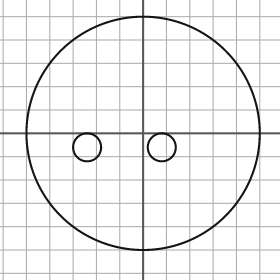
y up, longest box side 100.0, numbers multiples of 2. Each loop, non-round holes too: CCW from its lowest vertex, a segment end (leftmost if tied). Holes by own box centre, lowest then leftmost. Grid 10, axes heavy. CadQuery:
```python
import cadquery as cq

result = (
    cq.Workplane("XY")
    .moveTo(0.0, 0.0)
    .circle(50.0)
    .moveTo(-24.0, -6.0)
    .circle(6.0)
    .moveTo(8.0, -6.0)
    .circle(6.0)
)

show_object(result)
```